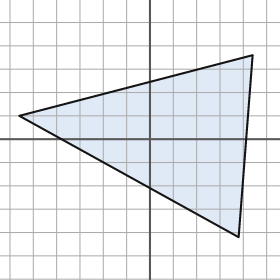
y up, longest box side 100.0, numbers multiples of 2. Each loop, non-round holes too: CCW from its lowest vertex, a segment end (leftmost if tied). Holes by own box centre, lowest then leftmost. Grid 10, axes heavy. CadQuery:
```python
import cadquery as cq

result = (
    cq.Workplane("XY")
    .moveTo(38.0, -42.0)
    .lineTo(44.0, 36.0)
    .lineTo(-56.0, 10.0)
    .close()
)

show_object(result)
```